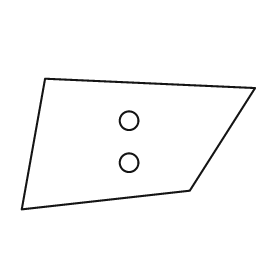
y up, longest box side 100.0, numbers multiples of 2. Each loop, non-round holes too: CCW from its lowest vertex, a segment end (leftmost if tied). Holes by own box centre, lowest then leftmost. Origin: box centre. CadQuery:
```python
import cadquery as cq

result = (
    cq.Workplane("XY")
    .moveTo(-50.0, -28.0)
    .lineTo(22.0, -20.0)
    .lineTo(50.0, 24.0)
    .lineTo(-40.0, 28.0)
    .close()
    .moveTo(-4.0, -8.0)
    .circle(4.0)
    .moveTo(-4.0, 10.0)
    .circle(4.0)
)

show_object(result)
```